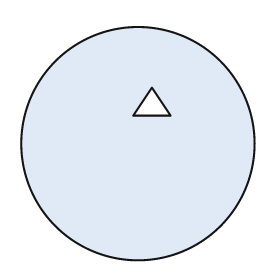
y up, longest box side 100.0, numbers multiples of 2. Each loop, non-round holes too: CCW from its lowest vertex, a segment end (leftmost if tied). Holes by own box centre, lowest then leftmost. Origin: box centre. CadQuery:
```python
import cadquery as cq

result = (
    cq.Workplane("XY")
    .moveTo(0.0, 0.0)
    .circle(50.0)
    .moveTo(-2.0, 12.0)
    .lineTo(14.0, 12.0)
    .lineTo(6.0, 24.0)
    .close()
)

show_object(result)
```